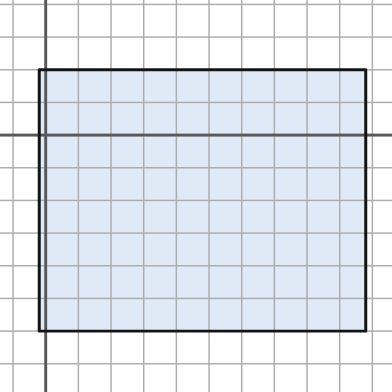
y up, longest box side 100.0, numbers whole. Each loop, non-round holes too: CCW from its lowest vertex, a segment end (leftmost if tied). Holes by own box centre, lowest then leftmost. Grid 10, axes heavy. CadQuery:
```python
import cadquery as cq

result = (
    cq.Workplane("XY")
    .moveTo(-2.0, -60.0)
    .lineTo(98.0, -60.0)
    .lineTo(98.0, 20.0)
    .lineTo(-2.0, 20.0)
    .close()
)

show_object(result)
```